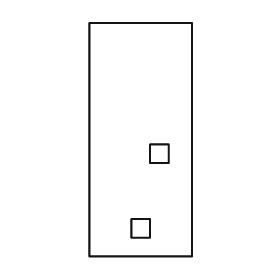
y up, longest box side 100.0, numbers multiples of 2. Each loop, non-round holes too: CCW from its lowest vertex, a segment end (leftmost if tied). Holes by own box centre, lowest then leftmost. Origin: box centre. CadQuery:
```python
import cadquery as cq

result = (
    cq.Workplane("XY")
    .moveTo(-22.0, -50.0)
    .lineTo(22.0, -50.0)
    .lineTo(22.0, 50.0)
    .lineTo(-22.0, 50.0)
    .close()
    .moveTo(-4.0, -42.0)
    .lineTo(4.0, -42.0)
    .lineTo(4.0, -34.0)
    .lineTo(-4.0, -34.0)
    .close()
    .moveTo(4.0, -10.0)
    .lineTo(12.0, -10.0)
    .lineTo(12.0, -2.0)
    .lineTo(4.0, -2.0)
    .close()
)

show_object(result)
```